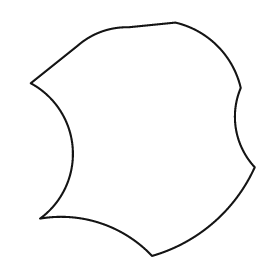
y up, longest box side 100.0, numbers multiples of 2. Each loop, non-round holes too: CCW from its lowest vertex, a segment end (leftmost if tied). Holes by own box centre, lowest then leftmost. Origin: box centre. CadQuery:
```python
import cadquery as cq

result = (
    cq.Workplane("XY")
    .moveTo(4.0, -50.0)
    .threePointArc((30.0, -36.0), (48.0, -12.0))
    .threePointArc((40.0, 4.0), (42.0, 22.0))
    .threePointArc((32.0, 40.0), (14.0, 50.0))
    .lineTo(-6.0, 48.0)
    .threePointArc((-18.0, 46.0), (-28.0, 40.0))
    .lineTo(-48.0, 24.0)
    .threePointArc((-30.0, -4.0), (-44.0, -34.0))
    .threePointArc((-18.0, -36.0), (4.0, -50.0))
    .close()
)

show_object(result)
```